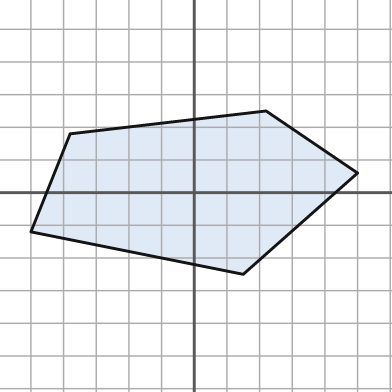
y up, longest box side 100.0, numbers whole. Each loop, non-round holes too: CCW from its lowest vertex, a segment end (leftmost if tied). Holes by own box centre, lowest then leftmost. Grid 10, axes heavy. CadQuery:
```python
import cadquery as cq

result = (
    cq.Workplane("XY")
    .moveTo(15.0, -25.0)
    .lineTo(50.0, 6.0)
    .lineTo(22.0, 25.0)
    .lineTo(-38.0, 18.0)
    .lineTo(-50.0, -12.0)
    .close()
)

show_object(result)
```